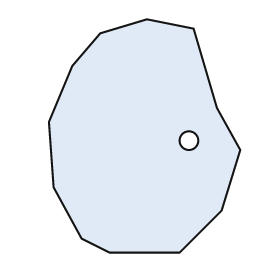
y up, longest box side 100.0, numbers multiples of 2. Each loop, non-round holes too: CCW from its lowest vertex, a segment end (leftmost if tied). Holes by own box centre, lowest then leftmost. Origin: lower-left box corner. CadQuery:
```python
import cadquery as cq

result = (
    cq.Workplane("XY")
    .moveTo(26.0, 0.0)
    .lineTo(56.0, 0.0)
    .lineTo(74.0, 18.0)
    .lineTo(82.0, 44.0)
    .lineTo(72.0, 62.0)
    .lineTo(62.0, 96.0)
    .lineTo(42.0, 100.0)
    .lineTo(22.0, 94.0)
    .lineTo(10.0, 80.0)
    .lineTo(0.0, 56.0)
    .lineTo(2.0, 28.0)
    .lineTo(14.0, 6.0)
    .close()
    .moveTo(60.0, 48.0)
    .circle(4.0)
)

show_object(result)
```